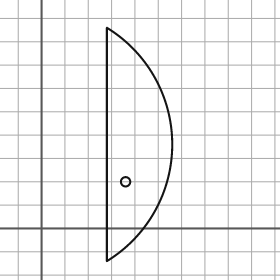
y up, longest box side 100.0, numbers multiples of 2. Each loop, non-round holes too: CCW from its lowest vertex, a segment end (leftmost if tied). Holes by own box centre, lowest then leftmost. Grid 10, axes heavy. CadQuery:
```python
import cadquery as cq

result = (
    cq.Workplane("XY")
    .moveTo(28.0, -14.0)
    .threePointArc((56.0, 36.0), (28.0, 86.0))
    .close()
    .moveTo(36.0, 20.0)
    .circle(2.0)
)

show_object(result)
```